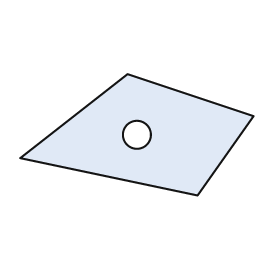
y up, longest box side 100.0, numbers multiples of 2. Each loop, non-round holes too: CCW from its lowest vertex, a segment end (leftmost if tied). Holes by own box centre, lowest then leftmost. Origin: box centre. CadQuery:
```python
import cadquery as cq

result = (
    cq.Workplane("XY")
    .moveTo(26.0, -26.0)
    .lineTo(50.0, 8.0)
    .lineTo(-4.0, 26.0)
    .lineTo(-50.0, -10.0)
    .close()
    .moveTo(0.0, 0.0)
    .circle(6.0)
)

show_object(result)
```